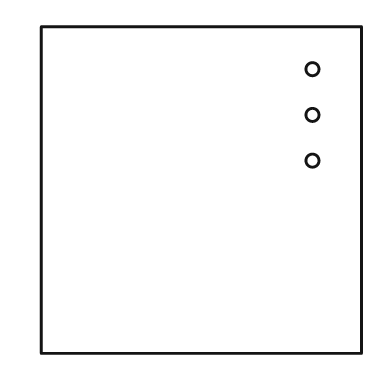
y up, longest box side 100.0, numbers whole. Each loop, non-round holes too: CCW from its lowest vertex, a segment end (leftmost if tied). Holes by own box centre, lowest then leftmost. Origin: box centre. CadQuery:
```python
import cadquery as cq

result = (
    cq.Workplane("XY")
    .moveTo(-49.0, -50.0)
    .lineTo(49.0, -50.0)
    .lineTo(49.0, 50.0)
    .lineTo(-49.0, 50.0)
    .close()
    .moveTo(34.0, 9.0)
    .circle(2.0)
    .moveTo(34.0, 23.0)
    .circle(2.0)
    .moveTo(34.0, 37.0)
    .circle(2.0)
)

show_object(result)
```